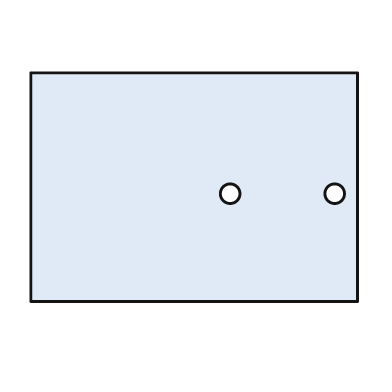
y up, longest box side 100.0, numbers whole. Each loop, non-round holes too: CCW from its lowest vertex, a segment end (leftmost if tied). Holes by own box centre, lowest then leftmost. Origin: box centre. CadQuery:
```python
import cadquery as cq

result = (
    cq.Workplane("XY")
    .moveTo(-50.0, -35.0)
    .lineTo(50.0, -35.0)
    .lineTo(50.0, 35.0)
    .lineTo(-50.0, 35.0)
    .close()
    .moveTo(11.0, -2.0)
    .circle(3.0)
    .moveTo(43.0, -2.0)
    .circle(3.0)
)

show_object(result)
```